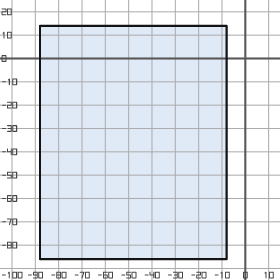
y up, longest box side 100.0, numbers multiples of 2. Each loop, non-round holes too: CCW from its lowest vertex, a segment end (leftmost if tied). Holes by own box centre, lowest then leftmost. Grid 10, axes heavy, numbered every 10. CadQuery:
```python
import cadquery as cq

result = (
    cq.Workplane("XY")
    .moveTo(-88.0, -86.0)
    .lineTo(-8.0, -86.0)
    .lineTo(-8.0, 14.0)
    .lineTo(-88.0, 14.0)
    .close()
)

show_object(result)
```